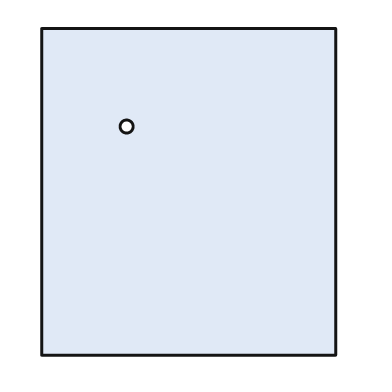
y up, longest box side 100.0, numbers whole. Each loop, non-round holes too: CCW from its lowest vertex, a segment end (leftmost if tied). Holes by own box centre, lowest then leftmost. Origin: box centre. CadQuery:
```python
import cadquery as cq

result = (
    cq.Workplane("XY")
    .moveTo(-45.0, -50.0)
    .lineTo(45.0, -50.0)
    .lineTo(45.0, 50.0)
    .lineTo(-45.0, 50.0)
    .close()
    .moveTo(-19.0, 20.0)
    .circle(2.0)
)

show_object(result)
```